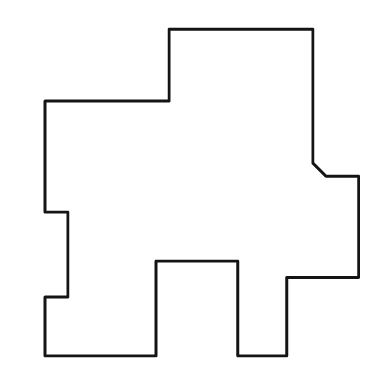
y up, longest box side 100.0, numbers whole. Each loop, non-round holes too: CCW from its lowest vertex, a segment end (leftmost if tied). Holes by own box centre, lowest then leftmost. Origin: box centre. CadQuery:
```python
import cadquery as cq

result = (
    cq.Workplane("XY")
    .moveTo(-48.0, -50.0)
    .lineTo(-14.0, -50.0)
    .lineTo(-14.0, -21.0)
    .lineTo(11.0, -21.0)
    .lineTo(11.0, -50.0)
    .lineTo(26.0, -50.0)
    .lineTo(26.0, -26.0)
    .lineTo(48.0, -26.0)
    .lineTo(48.0, 5.0)
    .lineTo(38.0, 5.0)
    .lineTo(34.0, 9.0)
    .lineTo(34.0, 50.0)
    .lineTo(-10.0, 50.0)
    .lineTo(-10.0, 28.0)
    .lineTo(-48.0, 28.0)
    .lineTo(-48.0, -6.0)
    .lineTo(-41.0, -6.0)
    .lineTo(-41.0, -32.0)
    .lineTo(-48.0, -32.0)
    .close()
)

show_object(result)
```